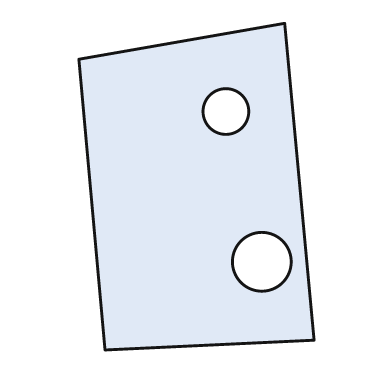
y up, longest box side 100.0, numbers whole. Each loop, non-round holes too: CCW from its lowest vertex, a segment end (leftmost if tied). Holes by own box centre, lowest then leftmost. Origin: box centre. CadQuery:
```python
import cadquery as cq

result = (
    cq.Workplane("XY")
    .moveTo(-28.0, -50.0)
    .lineTo(36.0, -47.0)
    .lineTo(27.0, 50.0)
    .lineTo(-36.0, 39.0)
    .close()
    .moveTo(20.0, -23.0)
    .circle(9.0)
    .moveTo(9.0, 23.0)
    .circle(7.0)
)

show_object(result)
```